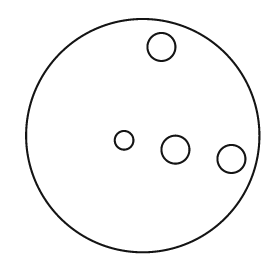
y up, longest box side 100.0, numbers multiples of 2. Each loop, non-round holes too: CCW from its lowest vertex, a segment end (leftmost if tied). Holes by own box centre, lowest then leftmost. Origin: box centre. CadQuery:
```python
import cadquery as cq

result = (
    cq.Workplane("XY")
    .moveTo(0.0, 0.0)
    .circle(50.0)
    .moveTo(38.0, -10.0)
    .circle(6.0)
    .moveTo(14.0, -6.0)
    .circle(6.0)
    .moveTo(-8.0, -2.0)
    .circle(4.0)
    .moveTo(8.0, 38.0)
    .circle(6.0)
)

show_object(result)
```